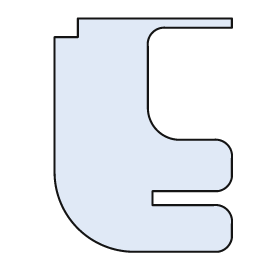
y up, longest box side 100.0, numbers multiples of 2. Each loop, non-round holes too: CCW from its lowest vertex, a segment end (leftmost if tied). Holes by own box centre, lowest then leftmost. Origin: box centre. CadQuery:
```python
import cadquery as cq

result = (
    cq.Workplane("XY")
    .moveTo(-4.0, -50.0)
    .lineTo(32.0, -50.0)
    .threePointArc((36.0, -48.0), (38.0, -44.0))
    .lineTo(38.0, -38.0)
    .threePointArc((36.0, -32.0), (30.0, -30.0))
    .lineTo(4.0, -30.0)
    .lineTo(4.0, -24.0)
    .lineTo(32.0, -24.0)
    .threePointArc((36.0, -22.0), (38.0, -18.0))
    .lineTo(38.0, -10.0)
    .threePointArc((36.0, -4.0), (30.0, -2.0))
    .lineTo(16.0, -2.0)
    .threePointArc((6.0, 2.0), (2.0, 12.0))
    .lineTo(2.0, 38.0)
    .threePointArc((4.0, 44.0), (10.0, 46.0))
    .lineTo(38.0, 46.0)
    .lineTo(38.0, 50.0)
    .lineTo(-28.0, 50.0)
    .lineTo(-28.0, 42.0)
    .lineTo(-38.0, 42.0)
    .lineTo(-38.0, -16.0)
    .threePointArc((-28.0, -40.0), (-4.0, -50.0))
    .close()
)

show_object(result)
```